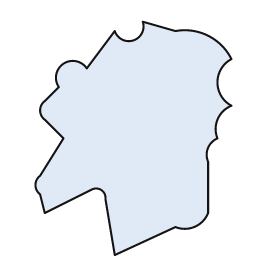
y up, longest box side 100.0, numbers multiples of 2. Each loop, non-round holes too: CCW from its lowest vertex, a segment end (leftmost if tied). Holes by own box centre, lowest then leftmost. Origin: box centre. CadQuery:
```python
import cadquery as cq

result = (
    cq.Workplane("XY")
    .moveTo(-8.0, -50.0)
    .lineTo(18.0, -38.0)
    .threePointArc((26.0, -38.0), (32.0, -32.0))
    .lineTo(32.0, -10.0)
    .threePointArc((32.0, -4.0), (36.0, 0.0))
    .threePointArc((36.0, 8.0), (42.0, 14.0))
    .threePointArc((36.0, 24.0), (42.0, 34.0))
    .threePointArc((32.0, 44.0), (18.0, 46.0))
    .lineTo(4.0, 50.0)
    .threePointArc((0.0, 42.0), (-8.0, 46.0))
    .lineTo(-20.0, 30.0)
    .threePointArc((-30.0, 32.0), (-32.0, 22.0))
    .lineTo(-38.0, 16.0)
    .threePointArc((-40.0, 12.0), (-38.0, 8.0))
    .lineTo(-30.0, 0.0)
    .lineTo(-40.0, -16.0)
    .threePointArc((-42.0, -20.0), (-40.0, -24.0))
    .lineTo(-38.0, -32.0)
    .lineTo(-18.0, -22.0)
    .threePointArc((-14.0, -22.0), (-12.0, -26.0))
    .close()
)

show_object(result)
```